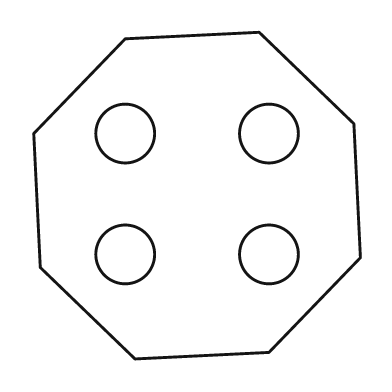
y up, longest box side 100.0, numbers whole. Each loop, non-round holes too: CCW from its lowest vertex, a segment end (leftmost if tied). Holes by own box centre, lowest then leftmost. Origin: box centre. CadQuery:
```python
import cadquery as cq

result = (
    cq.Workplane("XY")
    .moveTo(-19.0, -50.0)
    .lineTo(22.0, -48.0)
    .lineTo(50.0, -19.0)
    .lineTo(48.0, 22.0)
    .lineTo(19.0, 50.0)
    .lineTo(-22.0, 48.0)
    .lineTo(-50.0, 19.0)
    .lineTo(-48.0, -22.0)
    .close()
    .moveTo(-22.0, -18.0)
    .circle(9.0)
    .moveTo(22.0, -18.0)
    .circle(9.0)
    .moveTo(-22.0, 19.0)
    .circle(9.0)
    .moveTo(22.0, 19.0)
    .circle(9.0)
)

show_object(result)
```